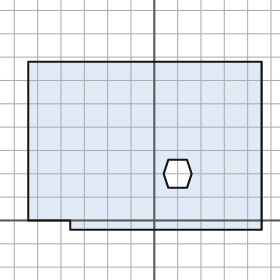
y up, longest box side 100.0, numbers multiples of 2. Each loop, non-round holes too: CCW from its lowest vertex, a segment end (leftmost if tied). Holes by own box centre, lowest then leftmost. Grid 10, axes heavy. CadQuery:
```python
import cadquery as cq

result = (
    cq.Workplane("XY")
    .moveTo(-36.0, -4.0)
    .lineTo(46.0, -4.0)
    .lineTo(46.0, 68.0)
    .lineTo(-54.0, 68.0)
    .lineTo(-54.0, 0.0)
    .lineTo(-36.0, 0.0)
    .close()
    .moveTo(6.0, 14.0)
    .lineTo(14.0, 14.0)
    .lineTo(16.0, 20.0)
    .lineTo(14.0, 26.0)
    .lineTo(6.0, 26.0)
    .lineTo(4.0, 20.0)
    .close()
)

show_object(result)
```